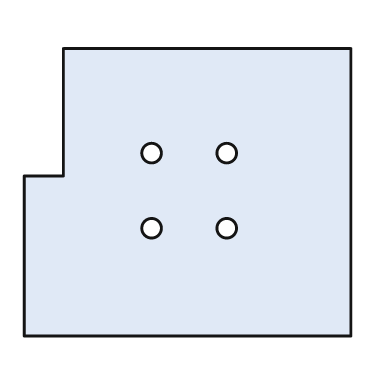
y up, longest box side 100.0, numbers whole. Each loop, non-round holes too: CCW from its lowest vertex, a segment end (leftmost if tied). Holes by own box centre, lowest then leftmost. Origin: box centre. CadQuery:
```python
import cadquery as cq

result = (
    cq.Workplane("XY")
    .moveTo(-50.0, -44.0)
    .lineTo(50.0, -44.0)
    .lineTo(50.0, 44.0)
    .lineTo(-38.0, 44.0)
    .lineTo(-38.0, 5.0)
    .lineTo(-50.0, 5.0)
    .close()
    .moveTo(-11.0, -11.0)
    .circle(3.0)
    .moveTo(12.0, -11.0)
    .circle(3.0)
    .moveTo(-11.0, 12.0)
    .circle(3.0)
    .moveTo(12.0, 12.0)
    .circle(3.0)
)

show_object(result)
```